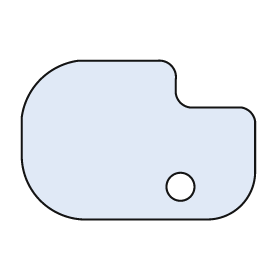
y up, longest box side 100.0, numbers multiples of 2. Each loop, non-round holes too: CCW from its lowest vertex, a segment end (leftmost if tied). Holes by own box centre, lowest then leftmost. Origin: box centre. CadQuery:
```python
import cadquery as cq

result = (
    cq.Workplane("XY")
    .moveTo(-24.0, -34.0)
    .lineTo(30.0, -34.0)
    .threePointArc((44.0, -28.0), (50.0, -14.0))
    .lineTo(50.0, 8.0)
    .threePointArc((48.0, 12.0), (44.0, 14.0))
    .lineTo(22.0, 14.0)
    .threePointArc((18.0, 16.0), (16.0, 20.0))
    .lineTo(16.0, 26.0)
    .threePointArc((14.0, 32.0), (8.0, 34.0))
    .lineTo(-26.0, 34.0)
    .threePointArc((-42.0, 26.0), (-50.0, 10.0))
    .lineTo(-50.0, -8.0)
    .threePointArc((-42.0, -26.0), (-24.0, -34.0))
    .close()
    .moveTo(18.0, -20.0)
    .circle(6.0)
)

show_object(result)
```